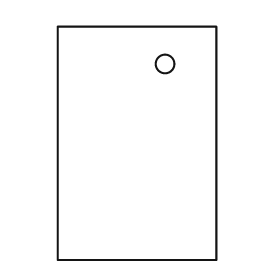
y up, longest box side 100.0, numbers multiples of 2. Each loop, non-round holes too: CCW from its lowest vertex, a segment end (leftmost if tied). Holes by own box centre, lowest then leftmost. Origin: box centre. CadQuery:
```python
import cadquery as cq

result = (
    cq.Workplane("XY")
    .moveTo(-34.0, -50.0)
    .lineTo(34.0, -50.0)
    .lineTo(34.0, 50.0)
    .lineTo(-34.0, 50.0)
    .close()
    .moveTo(12.0, 34.0)
    .circle(4.0)
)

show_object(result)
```